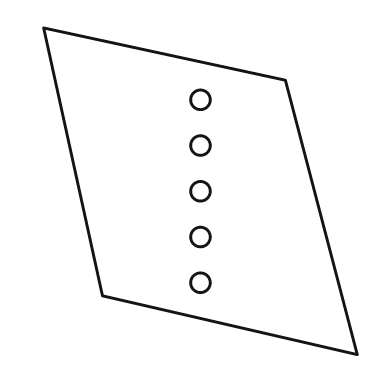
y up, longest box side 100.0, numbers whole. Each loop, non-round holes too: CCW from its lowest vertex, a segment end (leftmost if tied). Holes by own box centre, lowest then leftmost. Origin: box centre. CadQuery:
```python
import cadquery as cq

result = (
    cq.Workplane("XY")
    .moveTo(48.0, -50.0)
    .lineTo(26.0, 34.0)
    .lineTo(-48.0, 50.0)
    .lineTo(-30.0, -32.0)
    .close()
    .moveTo(0.0, -28.0)
    .circle(3.0)
    .moveTo(0.0, -14.0)
    .circle(3.0)
    .moveTo(0.0, 0.0)
    .circle(3.0)
    .moveTo(0.0, 14.0)
    .circle(3.0)
    .moveTo(0.0, 28.0)
    .circle(3.0)
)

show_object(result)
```